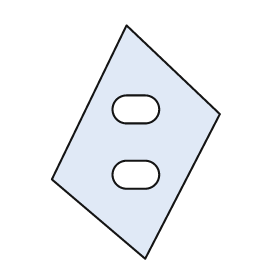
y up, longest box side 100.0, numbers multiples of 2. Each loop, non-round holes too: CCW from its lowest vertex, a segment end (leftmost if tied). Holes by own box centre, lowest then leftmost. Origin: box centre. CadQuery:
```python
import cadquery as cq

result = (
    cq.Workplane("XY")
    .moveTo(4.0, -50.0)
    .lineTo(36.0, 12.0)
    .lineTo(-4.0, 50.0)
    .lineTo(-36.0, -16.0)
    .close()
    .moveTo(-4.0, -20.0)
    .lineTo(4.0, -20.0)
    .threePointArc((10.0, -14.0), (4.0, -8.0))
    .lineTo(-4.0, -8.0)
    .threePointArc((-10.0, -14.0), (-4.0, -20.0))
    .close()
    .moveTo(-4.0, 8.0)
    .lineTo(4.0, 8.0)
    .threePointArc((10.0, 14.0), (4.0, 20.0))
    .lineTo(-4.0, 20.0)
    .threePointArc((-10.0, 14.0), (-4.0, 8.0))
    .close()
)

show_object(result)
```